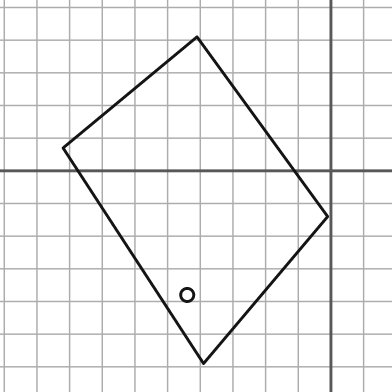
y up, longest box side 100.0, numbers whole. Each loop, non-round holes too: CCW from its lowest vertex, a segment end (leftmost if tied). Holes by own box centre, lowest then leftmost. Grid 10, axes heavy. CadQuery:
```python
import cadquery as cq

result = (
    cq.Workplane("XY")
    .moveTo(-39.0, -59.0)
    .lineTo(-1.0, -14.0)
    .lineTo(-41.0, 41.0)
    .lineTo(-82.0, 7.0)
    .close()
    .moveTo(-44.0, -38.0)
    .circle(2.0)
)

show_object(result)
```